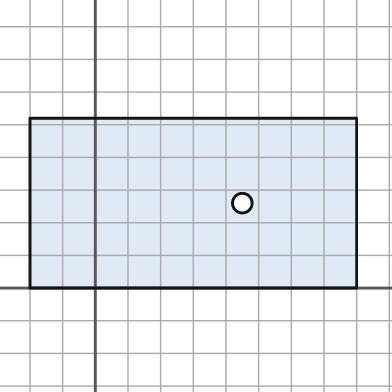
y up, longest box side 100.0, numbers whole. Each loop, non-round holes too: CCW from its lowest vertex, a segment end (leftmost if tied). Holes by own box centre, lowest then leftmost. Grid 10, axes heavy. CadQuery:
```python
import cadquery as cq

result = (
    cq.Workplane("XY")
    .moveTo(-20.0, 0.0)
    .lineTo(80.0, 0.0)
    .lineTo(80.0, 52.0)
    .lineTo(-20.0, 52.0)
    .close()
    .moveTo(45.0, 26.0)
    .circle(3.0)
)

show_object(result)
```